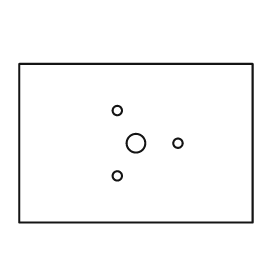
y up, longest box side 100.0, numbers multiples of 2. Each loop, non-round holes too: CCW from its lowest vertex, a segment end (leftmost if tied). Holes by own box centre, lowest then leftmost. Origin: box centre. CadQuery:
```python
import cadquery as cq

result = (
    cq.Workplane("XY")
    .moveTo(-50.0, -34.0)
    .lineTo(50.0, -34.0)
    .lineTo(50.0, 34.0)
    .lineTo(-50.0, 34.0)
    .close()
    .moveTo(-8.0, -14.0)
    .circle(2.0)
    .moveTo(0.0, 0.0)
    .circle(4.0)
    .moveTo(18.0, 0.0)
    .circle(2.0)
    .moveTo(-8.0, 14.0)
    .circle(2.0)
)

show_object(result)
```